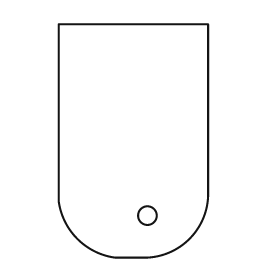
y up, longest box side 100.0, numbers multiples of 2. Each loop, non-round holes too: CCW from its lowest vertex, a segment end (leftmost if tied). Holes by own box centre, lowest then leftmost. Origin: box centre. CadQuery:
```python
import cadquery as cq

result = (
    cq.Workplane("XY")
    .moveTo(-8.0, -50.0)
    .lineTo(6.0, -50.0)
    .threePointArc((24.0, -42.0), (32.0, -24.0))
    .lineTo(32.0, 50.0)
    .lineTo(-32.0, 50.0)
    .lineTo(-32.0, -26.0)
    .threePointArc((-24.0, -42.0), (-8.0, -50.0))
    .close()
    .moveTo(6.0, -32.0)
    .circle(4.0)
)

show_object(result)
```